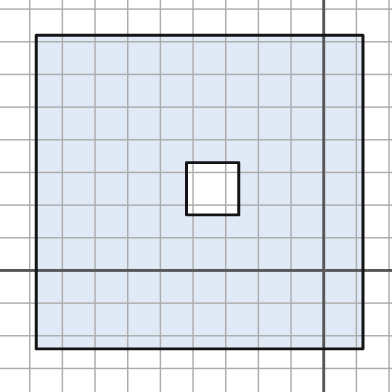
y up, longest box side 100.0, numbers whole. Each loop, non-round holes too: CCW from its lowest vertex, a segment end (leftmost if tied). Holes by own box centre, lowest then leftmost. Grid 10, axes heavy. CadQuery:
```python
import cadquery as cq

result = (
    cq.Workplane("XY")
    .moveTo(-88.0, -24.0)
    .lineTo(12.0, -24.0)
    .lineTo(12.0, 72.0)
    .lineTo(-88.0, 72.0)
    .close()
    .moveTo(-42.0, 17.0)
    .lineTo(-26.0, 17.0)
    .lineTo(-26.0, 33.0)
    .lineTo(-42.0, 33.0)
    .close()
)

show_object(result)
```